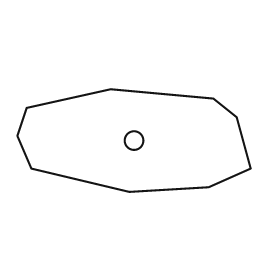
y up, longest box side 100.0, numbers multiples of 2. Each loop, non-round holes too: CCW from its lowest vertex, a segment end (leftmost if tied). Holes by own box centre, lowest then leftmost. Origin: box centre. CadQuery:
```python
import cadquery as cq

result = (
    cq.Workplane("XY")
    .moveTo(-2.0, -22.0)
    .lineTo(32.0, -20.0)
    .lineTo(50.0, -12.0)
    .lineTo(44.0, 10.0)
    .lineTo(34.0, 18.0)
    .lineTo(-10.0, 22.0)
    .lineTo(-46.0, 14.0)
    .lineTo(-50.0, 2.0)
    .lineTo(-44.0, -12.0)
    .close()
    .moveTo(0.0, 0.0)
    .circle(4.0)
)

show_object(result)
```